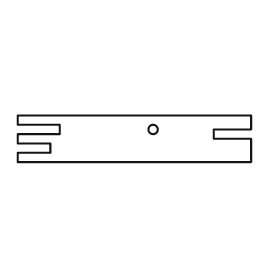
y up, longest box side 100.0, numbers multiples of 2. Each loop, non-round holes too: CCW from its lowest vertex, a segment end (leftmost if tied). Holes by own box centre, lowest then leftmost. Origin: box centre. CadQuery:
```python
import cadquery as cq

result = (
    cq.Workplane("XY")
    .moveTo(-50.0, -10.0)
    .lineTo(50.0, -10.0)
    .lineTo(50.0, 0.0)
    .lineTo(34.0, 0.0)
    .lineTo(34.0, 4.0)
    .lineTo(50.0, 4.0)
    .lineTo(50.0, 10.0)
    .lineTo(-50.0, 10.0)
    .lineTo(-50.0, 6.0)
    .lineTo(-32.0, 6.0)
    .lineTo(-32.0, 2.0)
    .lineTo(-50.0, 2.0)
    .lineTo(-50.0, -2.0)
    .lineTo(-36.0, -2.0)
    .lineTo(-36.0, -6.0)
    .lineTo(-50.0, -6.0)
    .close()
    .moveTo(8.0, 4.0)
    .circle(2.0)
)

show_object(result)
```